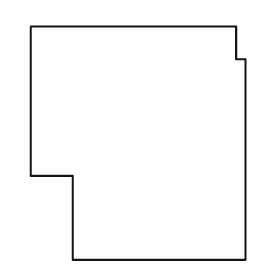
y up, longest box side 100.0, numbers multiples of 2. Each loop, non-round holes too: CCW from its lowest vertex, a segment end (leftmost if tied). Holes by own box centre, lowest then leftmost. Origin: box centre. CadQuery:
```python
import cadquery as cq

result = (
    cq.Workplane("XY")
    .moveTo(-28.0, -50.0)
    .lineTo(46.0, -50.0)
    .lineTo(46.0, 36.0)
    .lineTo(42.0, 36.0)
    .lineTo(42.0, 50.0)
    .lineTo(-46.0, 50.0)
    .lineTo(-46.0, -14.0)
    .lineTo(-28.0, -14.0)
    .close()
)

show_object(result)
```